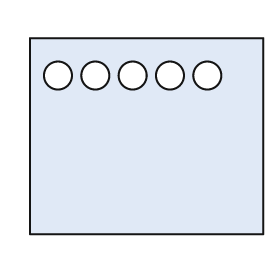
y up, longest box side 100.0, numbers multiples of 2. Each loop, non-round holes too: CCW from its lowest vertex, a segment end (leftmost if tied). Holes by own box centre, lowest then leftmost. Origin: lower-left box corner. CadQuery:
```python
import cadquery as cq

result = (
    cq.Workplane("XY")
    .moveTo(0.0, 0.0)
    .lineTo(100.0, 0.0)
    .lineTo(100.0, 84.0)
    .lineTo(0.0, 84.0)
    .close()
    .moveTo(12.0, 68.0)
    .circle(6.0)
    .moveTo(28.0, 68.0)
    .circle(6.0)
    .moveTo(44.0, 68.0)
    .circle(6.0)
    .moveTo(60.0, 68.0)
    .circle(6.0)
    .moveTo(76.0, 68.0)
    .circle(6.0)
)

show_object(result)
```